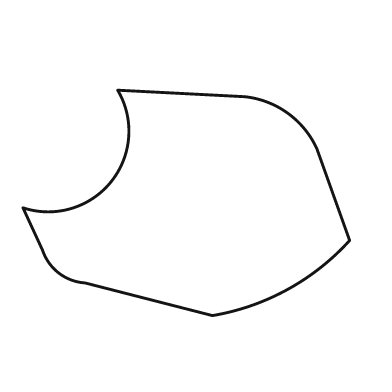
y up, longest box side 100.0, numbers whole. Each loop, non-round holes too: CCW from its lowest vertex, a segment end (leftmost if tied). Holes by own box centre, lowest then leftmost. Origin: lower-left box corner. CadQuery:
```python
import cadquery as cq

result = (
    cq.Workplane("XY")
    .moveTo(58.0, 0.0)
    .threePointArc((81.0, 8.0), (100.0, 23.0))
    .lineTo(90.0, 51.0)
    .threePointArc((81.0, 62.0), (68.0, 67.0))
    .lineTo(29.0, 69.0)
    .threePointArc((27.0, 41.0), (0.0, 33.0))
    .lineTo(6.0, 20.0)
    .threePointArc((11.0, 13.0), (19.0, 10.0))
    .close()
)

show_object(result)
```